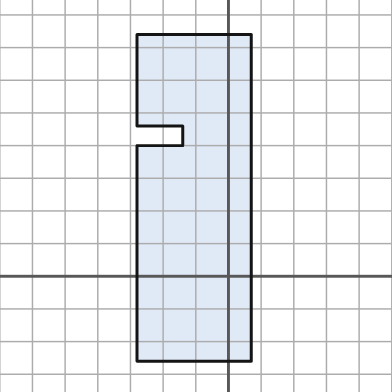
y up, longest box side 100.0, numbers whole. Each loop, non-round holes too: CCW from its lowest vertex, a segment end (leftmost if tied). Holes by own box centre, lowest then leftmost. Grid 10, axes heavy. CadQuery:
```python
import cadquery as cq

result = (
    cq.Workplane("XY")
    .moveTo(-28.0, -26.0)
    .lineTo(7.0, -26.0)
    .lineTo(7.0, 74.0)
    .lineTo(-28.0, 74.0)
    .lineTo(-28.0, 46.0)
    .lineTo(-14.0, 46.0)
    .lineTo(-14.0, 40.0)
    .lineTo(-28.0, 40.0)
    .close()
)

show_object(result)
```